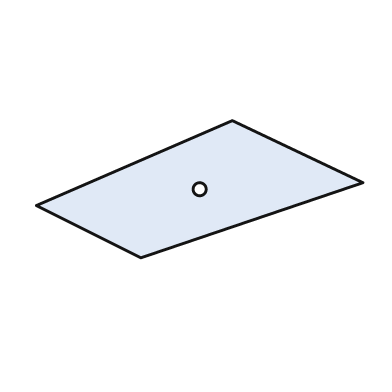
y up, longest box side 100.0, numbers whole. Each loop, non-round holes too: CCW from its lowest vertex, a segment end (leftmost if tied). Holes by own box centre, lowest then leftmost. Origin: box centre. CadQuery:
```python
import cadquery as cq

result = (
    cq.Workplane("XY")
    .moveTo(-18.0, -21.0)
    .lineTo(50.0, 2.0)
    .lineTo(10.0, 21.0)
    .lineTo(-50.0, -5.0)
    .close()
    .moveTo(0.0, 0.0)
    .circle(2.0)
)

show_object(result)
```